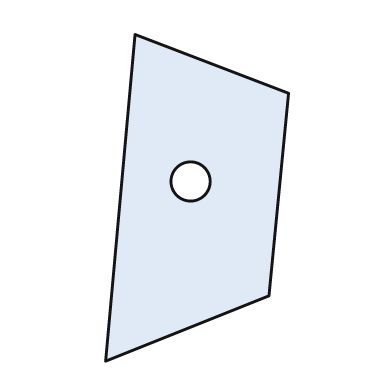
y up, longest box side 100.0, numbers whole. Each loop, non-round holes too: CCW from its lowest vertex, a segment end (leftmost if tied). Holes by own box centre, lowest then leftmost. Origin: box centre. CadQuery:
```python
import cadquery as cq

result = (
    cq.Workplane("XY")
    .moveTo(-28.0, -50.0)
    .lineTo(22.0, -30.0)
    .lineTo(28.0, 32.0)
    .lineTo(-19.0, 50.0)
    .close()
    .moveTo(-2.0, 5.0)
    .circle(6.0)
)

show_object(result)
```